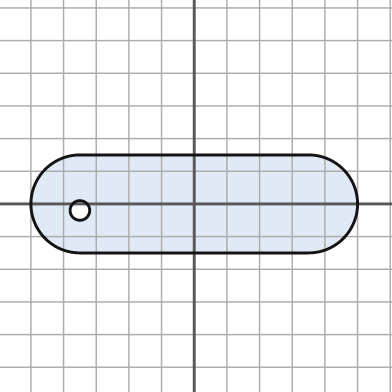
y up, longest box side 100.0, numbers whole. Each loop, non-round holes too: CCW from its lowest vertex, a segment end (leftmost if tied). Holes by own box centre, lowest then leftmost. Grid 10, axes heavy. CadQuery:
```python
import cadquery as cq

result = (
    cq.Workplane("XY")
    .moveTo(-35.0, -15.0)
    .lineTo(35.0, -15.0)
    .threePointArc((50.0, 0.0), (35.0, 15.0))
    .lineTo(-35.0, 15.0)
    .threePointArc((-50.0, 0.0), (-35.0, -15.0))
    .close()
    .moveTo(-35.0, -2.0)
    .circle(3.0)
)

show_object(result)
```